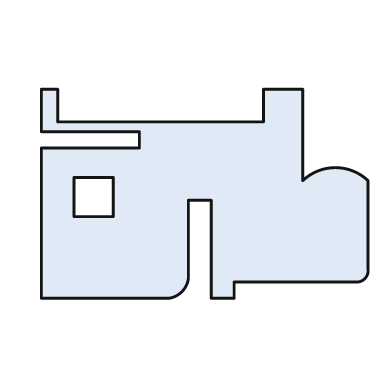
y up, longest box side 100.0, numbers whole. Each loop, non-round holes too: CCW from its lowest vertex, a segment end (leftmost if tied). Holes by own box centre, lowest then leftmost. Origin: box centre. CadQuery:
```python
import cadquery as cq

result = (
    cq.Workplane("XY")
    .moveTo(-50.0, -32.0)
    .lineTo(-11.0, -32.0)
    .threePointArc((-7.0, -30.0), (-5.0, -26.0))
    .lineTo(-5.0, -2.0)
    .lineTo(2.0, -2.0)
    .lineTo(2.0, -32.0)
    .lineTo(9.0, -32.0)
    .lineTo(9.0, -27.0)
    .lineTo(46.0, -27.0)
    .threePointArc((49.0, -26.0), (50.0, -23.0))
    .lineTo(50.0, 4.0)
    .threePointArc((40.0, 8.0), (30.0, 4.0))
    .lineTo(30.0, 32.0)
    .lineTo(18.0, 32.0)
    .lineTo(18.0, 22.0)
    .lineTo(-45.0, 22.0)
    .lineTo(-45.0, 32.0)
    .lineTo(-50.0, 32.0)
    .lineTo(-50.0, 19.0)
    .lineTo(-20.0, 19.0)
    .lineTo(-20.0, 14.0)
    .lineTo(-50.0, 14.0)
    .close()
    .moveTo(-40.0, -7.0)
    .lineTo(-28.0, -7.0)
    .lineTo(-28.0, 5.0)
    .lineTo(-40.0, 5.0)
    .close()
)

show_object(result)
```